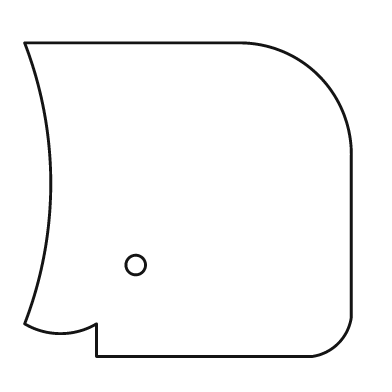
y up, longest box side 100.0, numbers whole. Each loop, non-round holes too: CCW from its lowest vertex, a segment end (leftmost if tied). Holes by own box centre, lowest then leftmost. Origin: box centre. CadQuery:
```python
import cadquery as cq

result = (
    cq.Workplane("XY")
    .moveTo(-28.0, -48.0)
    .lineTo(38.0, -48.0)
    .threePointArc((46.0, -44.0), (50.0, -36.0))
    .lineTo(50.0, 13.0)
    .threePointArc((40.0, 38.0), (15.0, 48.0))
    .lineTo(-50.0, 48.0)
    .threePointArc((-42.0, 5.0), (-50.0, -38.0))
    .threePointArc((-39.0, -41.0), (-28.0, -38.0))
    .close()
    .moveTo(-16.0, -20.0)
    .circle(3.0)
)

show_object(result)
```